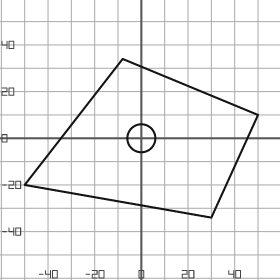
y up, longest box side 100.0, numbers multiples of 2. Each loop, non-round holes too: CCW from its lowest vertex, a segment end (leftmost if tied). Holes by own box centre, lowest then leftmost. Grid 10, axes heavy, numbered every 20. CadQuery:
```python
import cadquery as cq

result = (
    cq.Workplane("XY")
    .moveTo(30.0, -34.0)
    .lineTo(50.0, 10.0)
    .lineTo(-8.0, 34.0)
    .lineTo(-50.0, -20.0)
    .close()
    .moveTo(0.0, 0.0)
    .circle(6.0)
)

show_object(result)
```